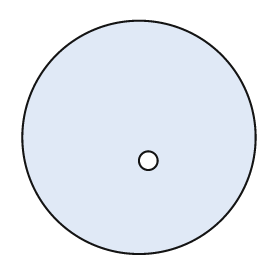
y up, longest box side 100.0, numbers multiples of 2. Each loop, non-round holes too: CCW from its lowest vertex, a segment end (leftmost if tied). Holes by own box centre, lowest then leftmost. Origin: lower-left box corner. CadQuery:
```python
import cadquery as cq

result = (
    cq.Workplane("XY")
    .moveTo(50.0, 50.0)
    .circle(50.0)
    .moveTo(54.0, 40.0)
    .circle(4.0)
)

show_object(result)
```